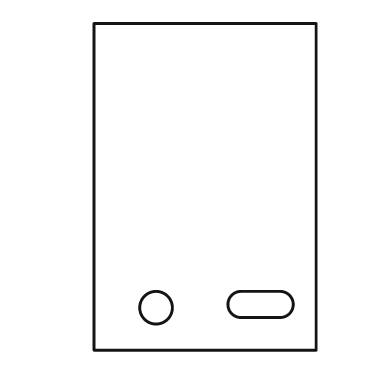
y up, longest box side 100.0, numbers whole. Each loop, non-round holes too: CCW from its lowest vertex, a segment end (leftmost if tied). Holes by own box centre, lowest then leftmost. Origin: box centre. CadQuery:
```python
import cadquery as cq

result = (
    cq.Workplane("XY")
    .moveTo(-34.0, -50.0)
    .lineTo(34.0, -50.0)
    .lineTo(34.0, 50.0)
    .lineTo(-34.0, 50.0)
    .close()
    .moveTo(-15.0, -37.0)
    .circle(5.0)
    .moveTo(11.0, -40.0)
    .lineTo(23.0, -40.0)
    .threePointArc((27.0, -36.0), (23.0, -32.0))
    .lineTo(11.0, -32.0)
    .threePointArc((7.0, -36.0), (11.0, -40.0))
    .close()
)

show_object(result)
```